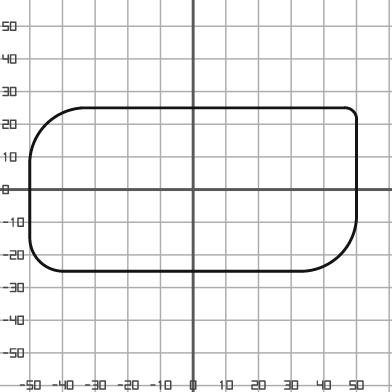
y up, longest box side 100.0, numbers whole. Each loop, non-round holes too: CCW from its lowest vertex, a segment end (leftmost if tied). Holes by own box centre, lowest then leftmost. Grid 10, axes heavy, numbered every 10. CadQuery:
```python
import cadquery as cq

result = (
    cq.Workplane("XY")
    .moveTo(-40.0, -25.0)
    .lineTo(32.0, -25.0)
    .threePointArc((45.0, -20.0), (50.0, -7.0))
    .lineTo(50.0, 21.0)
    .threePointArc((49.0, 24.0), (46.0, 25.0))
    .lineTo(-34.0, 25.0)
    .threePointArc((-45.0, 20.0), (-50.0, 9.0))
    .lineTo(-50.0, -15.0)
    .threePointArc((-47.0, -22.0), (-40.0, -25.0))
    .close()
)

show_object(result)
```